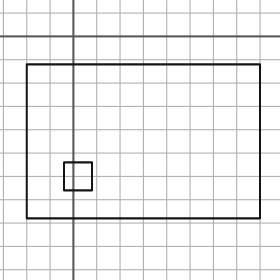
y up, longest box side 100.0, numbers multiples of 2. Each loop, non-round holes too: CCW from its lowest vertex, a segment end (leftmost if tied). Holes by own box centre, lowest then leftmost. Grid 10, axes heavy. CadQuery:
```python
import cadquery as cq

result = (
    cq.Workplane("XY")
    .moveTo(-20.0, -78.0)
    .lineTo(80.0, -78.0)
    .lineTo(80.0, -12.0)
    .lineTo(-20.0, -12.0)
    .close()
    .moveTo(-4.0, -66.0)
    .lineTo(8.0, -66.0)
    .lineTo(8.0, -54.0)
    .lineTo(-4.0, -54.0)
    .close()
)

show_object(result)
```